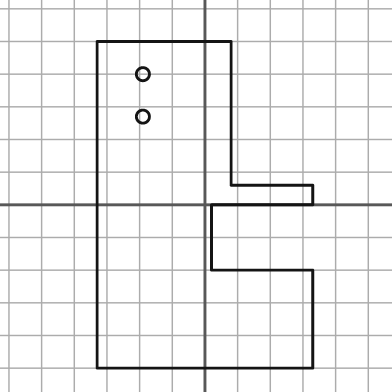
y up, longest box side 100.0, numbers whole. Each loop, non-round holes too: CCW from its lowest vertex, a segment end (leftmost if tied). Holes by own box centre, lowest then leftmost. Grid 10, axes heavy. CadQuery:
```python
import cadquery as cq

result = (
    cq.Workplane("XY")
    .moveTo(-33.0, -50.0)
    .lineTo(33.0, -50.0)
    .lineTo(33.0, -20.0)
    .lineTo(2.0, -20.0)
    .lineTo(2.0, 0.0)
    .lineTo(33.0, 0.0)
    .lineTo(33.0, 6.0)
    .lineTo(8.0, 6.0)
    .lineTo(8.0, 50.0)
    .lineTo(-33.0, 50.0)
    .close()
    .moveTo(-19.0, 27.0)
    .circle(2.0)
    .moveTo(-19.0, 40.0)
    .circle(2.0)
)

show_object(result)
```